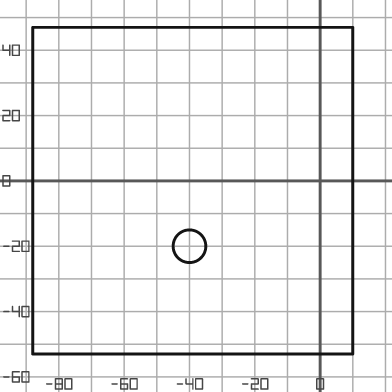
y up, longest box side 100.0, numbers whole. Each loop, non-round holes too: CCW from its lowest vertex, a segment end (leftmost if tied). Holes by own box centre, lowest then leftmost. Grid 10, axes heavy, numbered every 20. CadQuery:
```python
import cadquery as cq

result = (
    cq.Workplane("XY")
    .moveTo(-88.0, -53.0)
    .lineTo(10.0, -53.0)
    .lineTo(10.0, 47.0)
    .lineTo(-88.0, 47.0)
    .close()
    .moveTo(-40.0, -20.0)
    .circle(5.0)
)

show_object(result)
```